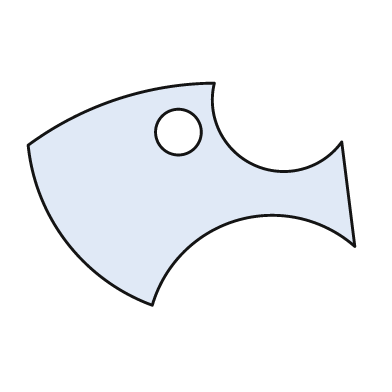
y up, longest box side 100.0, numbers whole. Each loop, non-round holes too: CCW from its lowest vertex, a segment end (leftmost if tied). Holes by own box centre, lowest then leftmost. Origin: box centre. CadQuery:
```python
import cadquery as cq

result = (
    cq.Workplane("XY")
    .moveTo(-12.0, -34.0)
    .threePointArc((14.0, -8.0), (50.0, -16.0))
    .lineTo(46.0, 16.0)
    .threePointArc((19.0, 9.0), (7.0, 34.0))
    .threePointArc((-23.0, 29.0), (-50.0, 15.0))
    .threePointArc((-38.0, -15.0), (-12.0, -34.0))
    .close()
    .moveTo(-4.0, 19.0)
    .circle(7.0)
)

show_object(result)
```